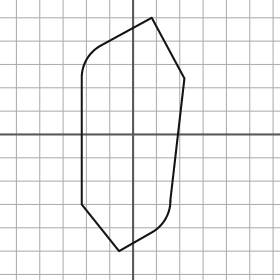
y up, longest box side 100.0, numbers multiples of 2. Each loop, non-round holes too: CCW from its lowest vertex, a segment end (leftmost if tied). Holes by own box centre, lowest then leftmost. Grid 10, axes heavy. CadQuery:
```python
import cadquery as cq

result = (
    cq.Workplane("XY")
    .moveTo(-6.0, -50.0)
    .lineTo(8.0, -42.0)
    .threePointArc((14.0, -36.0), (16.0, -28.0))
    .lineTo(22.0, 24.0)
    .lineTo(8.0, 50.0)
    .lineTo(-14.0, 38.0)
    .threePointArc((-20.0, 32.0), (-22.0, 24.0))
    .lineTo(-22.0, -30.0)
    .close()
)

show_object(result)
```